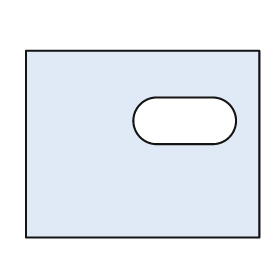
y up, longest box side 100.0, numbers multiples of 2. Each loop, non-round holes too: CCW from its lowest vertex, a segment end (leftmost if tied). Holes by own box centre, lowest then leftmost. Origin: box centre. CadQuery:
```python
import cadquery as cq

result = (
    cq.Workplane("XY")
    .moveTo(-50.0, -40.0)
    .lineTo(50.0, -40.0)
    .lineTo(50.0, 40.0)
    .lineTo(-50.0, 40.0)
    .close()
    .moveTo(6.0, 0.0)
    .lineTo(30.0, 0.0)
    .threePointArc((40.0, 10.0), (30.0, 20.0))
    .lineTo(6.0, 20.0)
    .threePointArc((-4.0, 10.0), (6.0, 0.0))
    .close()
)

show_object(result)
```